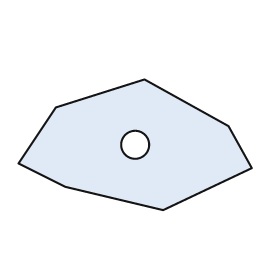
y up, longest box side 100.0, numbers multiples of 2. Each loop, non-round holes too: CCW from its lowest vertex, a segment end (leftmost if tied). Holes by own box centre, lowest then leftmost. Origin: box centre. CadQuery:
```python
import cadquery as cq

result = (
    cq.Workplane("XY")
    .moveTo(12.0, -28.0)
    .lineTo(50.0, -10.0)
    .lineTo(40.0, 8.0)
    .lineTo(4.0, 28.0)
    .lineTo(-34.0, 16.0)
    .lineTo(-50.0, -8.0)
    .lineTo(-30.0, -18.0)
    .close()
    .moveTo(0.0, 0.0)
    .circle(6.0)
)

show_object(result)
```